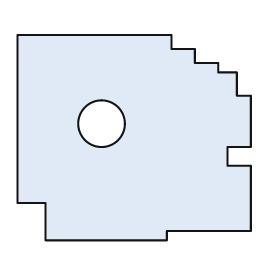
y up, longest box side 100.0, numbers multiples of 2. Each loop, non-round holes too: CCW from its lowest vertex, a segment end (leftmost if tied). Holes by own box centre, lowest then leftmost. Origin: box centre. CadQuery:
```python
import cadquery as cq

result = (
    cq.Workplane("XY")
    .moveTo(-38.0, -44.0)
    .lineTo(14.0, -44.0)
    .lineTo(14.0, -40.0)
    .lineTo(50.0, -40.0)
    .lineTo(50.0, -12.0)
    .lineTo(40.0, -12.0)
    .lineTo(40.0, -4.0)
    .lineTo(50.0, -4.0)
    .lineTo(50.0, 18.0)
    .lineTo(44.0, 18.0)
    .lineTo(44.0, 28.0)
    .lineTo(36.0, 28.0)
    .lineTo(36.0, 32.0)
    .lineTo(26.0, 32.0)
    .lineTo(26.0, 38.0)
    .lineTo(16.0, 38.0)
    .lineTo(16.0, 44.0)
    .lineTo(-50.0, 44.0)
    .lineTo(-50.0, -28.0)
    .lineTo(-38.0, -28.0)
    .close()
    .moveTo(-14.0, 6.0)
    .circle(10.0)
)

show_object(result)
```